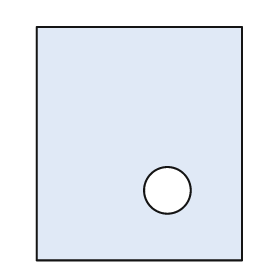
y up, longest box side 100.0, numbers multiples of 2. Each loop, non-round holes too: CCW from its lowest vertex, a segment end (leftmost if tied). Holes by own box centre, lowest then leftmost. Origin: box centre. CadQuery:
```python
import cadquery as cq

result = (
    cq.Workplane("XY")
    .moveTo(-44.0, -50.0)
    .lineTo(44.0, -50.0)
    .lineTo(44.0, 50.0)
    .lineTo(-44.0, 50.0)
    .close()
    .moveTo(12.0, -20.0)
    .circle(10.0)
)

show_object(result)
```